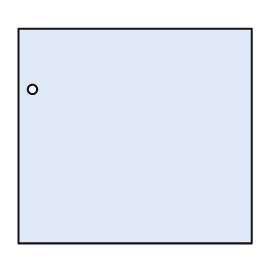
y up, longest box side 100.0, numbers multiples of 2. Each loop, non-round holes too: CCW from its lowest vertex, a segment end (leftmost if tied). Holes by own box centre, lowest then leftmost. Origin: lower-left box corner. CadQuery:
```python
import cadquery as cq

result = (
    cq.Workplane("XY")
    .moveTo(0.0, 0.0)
    .lineTo(100.0, 0.0)
    .lineTo(100.0, 92.0)
    .lineTo(0.0, 92.0)
    .close()
    .moveTo(6.0, 66.0)
    .circle(2.0)
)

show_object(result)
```